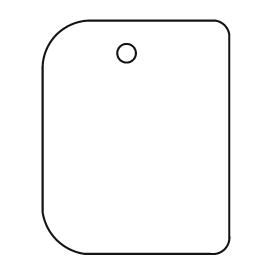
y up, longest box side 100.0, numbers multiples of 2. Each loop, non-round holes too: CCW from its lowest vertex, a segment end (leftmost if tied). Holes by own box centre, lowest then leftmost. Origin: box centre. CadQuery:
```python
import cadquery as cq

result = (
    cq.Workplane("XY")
    .moveTo(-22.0, -50.0)
    .lineTo(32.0, -50.0)
    .threePointArc((38.0, -48.0), (40.0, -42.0))
    .lineTo(40.0, 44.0)
    .threePointArc((38.0, 48.0), (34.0, 50.0))
    .lineTo(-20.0, 50.0)
    .threePointArc((-34.0, 44.0), (-40.0, 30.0))
    .lineTo(-40.0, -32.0)
    .threePointArc((-34.0, -44.0), (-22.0, -50.0))
    .close()
    .moveTo(-4.0, 36.0)
    .circle(4.0)
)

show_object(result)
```